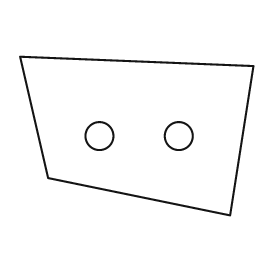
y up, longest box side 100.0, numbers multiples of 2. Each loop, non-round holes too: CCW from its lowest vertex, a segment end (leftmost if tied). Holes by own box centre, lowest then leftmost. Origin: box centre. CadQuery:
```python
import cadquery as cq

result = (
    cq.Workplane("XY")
    .moveTo(40.0, -34.0)
    .lineTo(50.0, 30.0)
    .lineTo(-50.0, 34.0)
    .lineTo(-38.0, -18.0)
    .close()
    .moveTo(-16.0, 0.0)
    .circle(6.0)
    .moveTo(18.0, 0.0)
    .circle(6.0)
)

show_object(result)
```